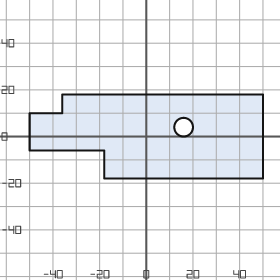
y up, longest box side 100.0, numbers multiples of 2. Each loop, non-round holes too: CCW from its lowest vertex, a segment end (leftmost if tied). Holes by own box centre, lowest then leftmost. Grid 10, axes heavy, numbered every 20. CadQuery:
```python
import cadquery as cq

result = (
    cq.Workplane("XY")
    .moveTo(-18.0, -18.0)
    .lineTo(50.0, -18.0)
    .lineTo(50.0, 18.0)
    .lineTo(-36.0, 18.0)
    .lineTo(-36.0, 10.0)
    .lineTo(-50.0, 10.0)
    .lineTo(-50.0, -6.0)
    .lineTo(-18.0, -6.0)
    .close()
    .moveTo(16.0, 4.0)
    .circle(4.0)
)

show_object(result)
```